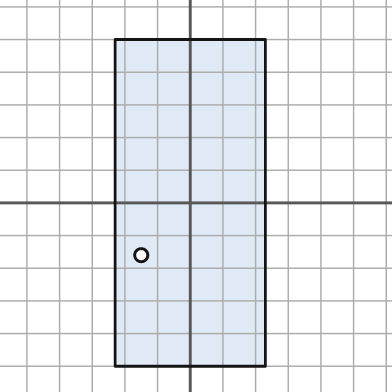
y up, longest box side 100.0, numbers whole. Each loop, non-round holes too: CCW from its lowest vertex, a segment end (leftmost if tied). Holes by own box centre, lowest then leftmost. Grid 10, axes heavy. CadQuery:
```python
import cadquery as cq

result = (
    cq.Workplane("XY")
    .moveTo(-23.0, -50.0)
    .lineTo(23.0, -50.0)
    .lineTo(23.0, 50.0)
    .lineTo(-23.0, 50.0)
    .close()
    .moveTo(-15.0, -16.0)
    .circle(2.0)
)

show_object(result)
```